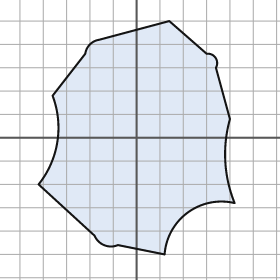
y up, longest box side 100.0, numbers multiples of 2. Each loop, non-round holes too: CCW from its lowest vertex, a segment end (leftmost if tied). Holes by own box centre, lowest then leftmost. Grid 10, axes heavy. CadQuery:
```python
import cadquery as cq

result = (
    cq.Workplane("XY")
    .moveTo(12.0, -50.0)
    .threePointArc((22.0, -32.0), (42.0, -28.0))
    .threePointArc((38.0, -10.0), (40.0, 8.0))
    .lineTo(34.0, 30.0)
    .threePointArc((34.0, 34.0), (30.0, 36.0))
    .lineTo(14.0, 50.0)
    .lineTo(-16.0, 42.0)
    .threePointArc((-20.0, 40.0), (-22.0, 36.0))
    .lineTo(-36.0, 18.0)
    .threePointArc((-34.0, -2.0), (-42.0, -20.0))
    .lineTo(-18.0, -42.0)
    .threePointArc((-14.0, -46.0), (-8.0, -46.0))
    .close()
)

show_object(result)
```